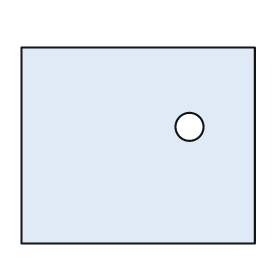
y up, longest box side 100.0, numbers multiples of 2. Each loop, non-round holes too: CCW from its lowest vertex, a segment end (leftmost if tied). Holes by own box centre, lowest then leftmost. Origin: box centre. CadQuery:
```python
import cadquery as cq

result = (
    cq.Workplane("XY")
    .moveTo(-50.0, -42.0)
    .lineTo(50.0, -42.0)
    .lineTo(50.0, 42.0)
    .lineTo(-50.0, 42.0)
    .close()
    .moveTo(22.0, 8.0)
    .circle(6.0)
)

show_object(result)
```